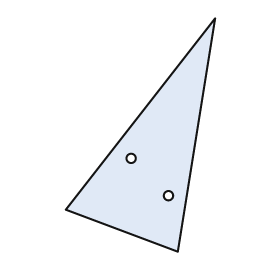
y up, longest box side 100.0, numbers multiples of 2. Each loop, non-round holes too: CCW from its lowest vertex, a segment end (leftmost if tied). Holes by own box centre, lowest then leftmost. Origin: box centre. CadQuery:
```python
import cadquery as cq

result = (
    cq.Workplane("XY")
    .moveTo(16.0, -50.0)
    .lineTo(32.0, 50.0)
    .lineTo(-32.0, -32.0)
    .close()
    .moveTo(12.0, -26.0)
    .circle(2.0)
    .moveTo(-4.0, -10.0)
    .circle(2.0)
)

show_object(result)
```